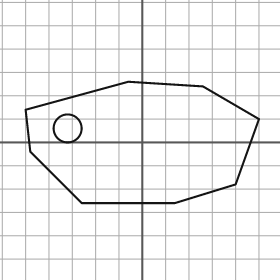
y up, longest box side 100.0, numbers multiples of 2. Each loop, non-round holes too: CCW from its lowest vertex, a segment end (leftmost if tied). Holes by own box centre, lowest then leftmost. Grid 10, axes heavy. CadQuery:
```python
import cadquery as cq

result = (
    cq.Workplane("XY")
    .moveTo(-26.0, -26.0)
    .lineTo(14.0, -26.0)
    .lineTo(40.0, -18.0)
    .lineTo(50.0, 10.0)
    .lineTo(26.0, 24.0)
    .lineTo(-6.0, 26.0)
    .lineTo(-50.0, 14.0)
    .lineTo(-48.0, -4.0)
    .close()
    .moveTo(-32.0, 6.0)
    .circle(6.0)
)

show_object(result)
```